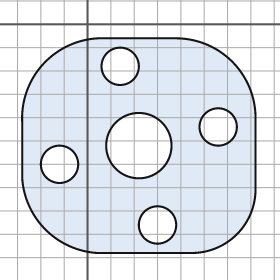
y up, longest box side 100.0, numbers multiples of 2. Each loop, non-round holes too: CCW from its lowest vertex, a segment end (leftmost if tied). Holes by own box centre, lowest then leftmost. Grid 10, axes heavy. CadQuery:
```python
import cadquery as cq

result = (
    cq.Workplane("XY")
    .moveTo(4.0, -98.0)
    .lineTo(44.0, -98.0)
    .threePointArc((64.0, -90.0), (72.0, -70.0))
    .lineTo(72.0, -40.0)
    .threePointArc((62.0, -16.0), (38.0, -6.0))
    .lineTo(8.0, -6.0)
    .threePointArc((-18.0, -16.0), (-28.0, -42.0))
    .lineTo(-28.0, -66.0)
    .threePointArc((-18.0, -88.0), (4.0, -98.0))
    .close()
    .moveTo(30.0, -86.0)
    .circle(8.0)
    .moveTo(-12.0, -60.0)
    .circle(8.0)
    .moveTo(22.0, -52.0)
    .circle(14.0)
    .moveTo(56.0, -44.0)
    .circle(8.0)
    .moveTo(14.0, -18.0)
    .circle(8.0)
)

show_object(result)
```